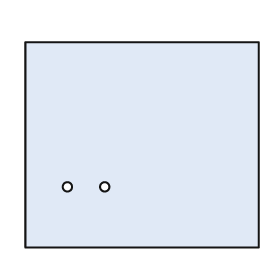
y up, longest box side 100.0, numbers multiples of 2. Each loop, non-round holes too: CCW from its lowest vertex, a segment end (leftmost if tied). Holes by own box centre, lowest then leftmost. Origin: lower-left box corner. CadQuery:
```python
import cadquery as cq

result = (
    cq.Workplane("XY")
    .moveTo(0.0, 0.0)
    .lineTo(100.0, 0.0)
    .lineTo(100.0, 88.0)
    .lineTo(0.0, 88.0)
    .close()
    .moveTo(18.0, 26.0)
    .circle(2.0)
    .moveTo(34.0, 26.0)
    .circle(2.0)
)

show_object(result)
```